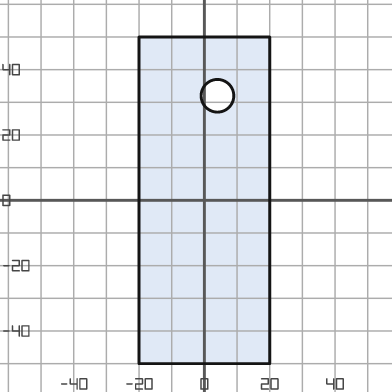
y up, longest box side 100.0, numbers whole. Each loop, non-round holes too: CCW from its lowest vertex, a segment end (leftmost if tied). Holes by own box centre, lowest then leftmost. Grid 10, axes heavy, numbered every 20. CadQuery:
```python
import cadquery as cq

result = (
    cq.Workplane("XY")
    .moveTo(-20.0, -50.0)
    .lineTo(20.0, -50.0)
    .lineTo(20.0, 50.0)
    .lineTo(-20.0, 50.0)
    .close()
    .moveTo(4.0, 32.0)
    .circle(5.0)
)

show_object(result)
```